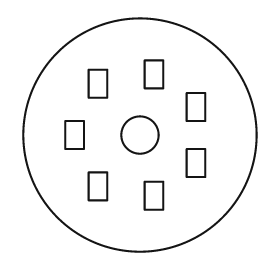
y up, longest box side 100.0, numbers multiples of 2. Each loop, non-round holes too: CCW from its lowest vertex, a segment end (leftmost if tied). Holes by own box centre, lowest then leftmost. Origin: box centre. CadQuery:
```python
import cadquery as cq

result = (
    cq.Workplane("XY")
    .moveTo(0.0, 0.0)
    .circle(50.0)
    .moveTo(2.0, -32.0)
    .lineTo(10.0, -32.0)
    .lineTo(10.0, -20.0)
    .lineTo(2.0, -20.0)
    .close()
    .moveTo(-22.0, -28.0)
    .lineTo(-14.0, -28.0)
    .lineTo(-14.0, -16.0)
    .lineTo(-22.0, -16.0)
    .close()
    .moveTo(20.0, -18.0)
    .lineTo(28.0, -18.0)
    .lineTo(28.0, -6.0)
    .lineTo(20.0, -6.0)
    .close()
    .moveTo(-32.0, -6.0)
    .lineTo(-24.0, -6.0)
    .lineTo(-24.0, 6.0)
    .lineTo(-32.0, 6.0)
    .close()
    .moveTo(0.0, 0.0)
    .circle(8.0)
    .moveTo(20.0, 6.0)
    .lineTo(28.0, 6.0)
    .lineTo(28.0, 18.0)
    .lineTo(20.0, 18.0)
    .close()
    .moveTo(-22.0, 16.0)
    .lineTo(-14.0, 16.0)
    .lineTo(-14.0, 28.0)
    .lineTo(-22.0, 28.0)
    .close()
    .moveTo(2.0, 20.0)
    .lineTo(10.0, 20.0)
    .lineTo(10.0, 32.0)
    .lineTo(2.0, 32.0)
    .close()
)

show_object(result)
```